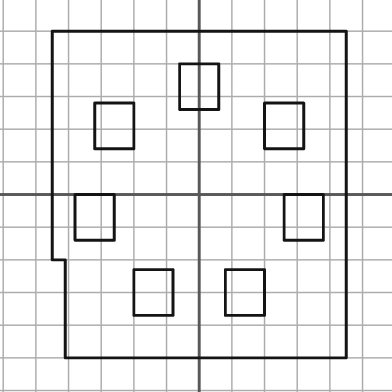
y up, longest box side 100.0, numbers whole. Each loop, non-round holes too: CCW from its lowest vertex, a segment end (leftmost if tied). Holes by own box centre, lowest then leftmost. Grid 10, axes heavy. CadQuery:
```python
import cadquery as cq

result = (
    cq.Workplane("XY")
    .moveTo(-41.0, -50.0)
    .lineTo(45.0, -50.0)
    .lineTo(45.0, 50.0)
    .lineTo(-45.0, 50.0)
    .lineTo(-45.0, -20.0)
    .lineTo(-41.0, -20.0)
    .close()
    .moveTo(-20.0, -37.0)
    .lineTo(-8.0, -37.0)
    .lineTo(-8.0, -23.0)
    .lineTo(-20.0, -23.0)
    .close()
    .moveTo(8.0, -37.0)
    .lineTo(20.0, -37.0)
    .lineTo(20.0, -23.0)
    .lineTo(8.0, -23.0)
    .close()
    .moveTo(-38.0, -14.0)
    .lineTo(-26.0, -14.0)
    .lineTo(-26.0, 0.0)
    .lineTo(-38.0, 0.0)
    .close()
    .moveTo(26.0, -14.0)
    .lineTo(38.0, -14.0)
    .lineTo(38.0, 0.0)
    .lineTo(26.0, 0.0)
    .close()
    .moveTo(-32.0, 14.0)
    .lineTo(-20.0, 14.0)
    .lineTo(-20.0, 28.0)
    .lineTo(-32.0, 28.0)
    .close()
    .moveTo(20.0, 14.0)
    .lineTo(32.0, 14.0)
    .lineTo(32.0, 28.0)
    .lineTo(20.0, 28.0)
    .close()
    .moveTo(-6.0, 26.0)
    .lineTo(6.0, 26.0)
    .lineTo(6.0, 40.0)
    .lineTo(-6.0, 40.0)
    .close()
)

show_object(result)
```